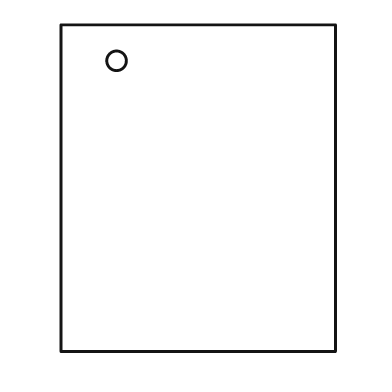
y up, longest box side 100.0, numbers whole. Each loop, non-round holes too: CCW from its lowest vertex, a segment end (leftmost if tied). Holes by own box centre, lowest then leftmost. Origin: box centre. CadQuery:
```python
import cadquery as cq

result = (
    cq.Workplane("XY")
    .moveTo(-42.0, -50.0)
    .lineTo(42.0, -50.0)
    .lineTo(42.0, 50.0)
    .lineTo(-42.0, 50.0)
    .close()
    .moveTo(-25.0, 39.0)
    .circle(3.0)
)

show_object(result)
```